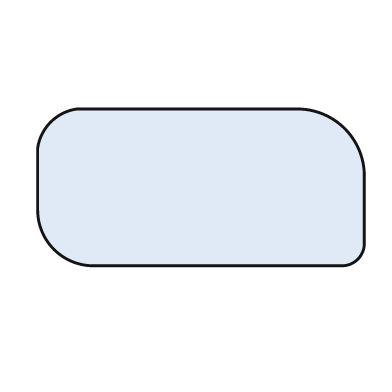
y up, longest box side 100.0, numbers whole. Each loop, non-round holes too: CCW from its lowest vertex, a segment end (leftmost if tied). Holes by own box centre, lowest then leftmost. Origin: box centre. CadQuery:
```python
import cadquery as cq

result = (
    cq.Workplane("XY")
    .moveTo(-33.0, -24.0)
    .lineTo(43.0, -24.0)
    .threePointArc((48.0, -22.0), (50.0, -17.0))
    .lineTo(50.0, 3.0)
    .threePointArc((44.0, 18.0), (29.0, 24.0))
    .lineTo(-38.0, 24.0)
    .threePointArc((-46.0, 20.0), (-50.0, 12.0))
    .lineTo(-50.0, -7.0)
    .threePointArc((-45.0, -19.0), (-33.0, -24.0))
    .close()
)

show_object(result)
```